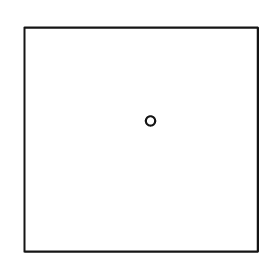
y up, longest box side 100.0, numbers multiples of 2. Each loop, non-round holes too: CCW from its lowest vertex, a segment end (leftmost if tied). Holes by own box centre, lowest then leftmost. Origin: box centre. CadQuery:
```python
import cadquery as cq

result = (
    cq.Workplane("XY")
    .moveTo(-50.0, -48.0)
    .lineTo(50.0, -48.0)
    .lineTo(50.0, 48.0)
    .lineTo(-50.0, 48.0)
    .close()
    .moveTo(4.0, 8.0)
    .circle(2.0)
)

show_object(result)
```